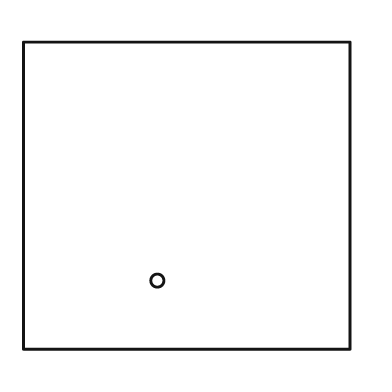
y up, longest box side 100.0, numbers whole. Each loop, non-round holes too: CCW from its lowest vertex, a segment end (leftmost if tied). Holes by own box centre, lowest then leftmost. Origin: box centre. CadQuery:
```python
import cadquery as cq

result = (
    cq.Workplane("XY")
    .moveTo(-50.0, -47.0)
    .lineTo(50.0, -47.0)
    .lineTo(50.0, 47.0)
    .lineTo(-50.0, 47.0)
    .close()
    .moveTo(-9.0, -26.0)
    .circle(2.0)
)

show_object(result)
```